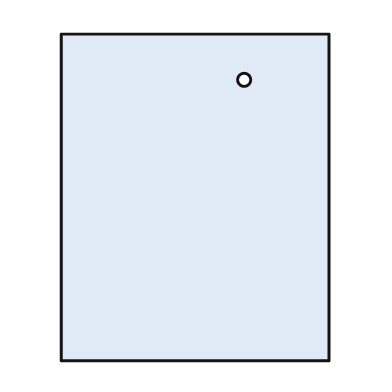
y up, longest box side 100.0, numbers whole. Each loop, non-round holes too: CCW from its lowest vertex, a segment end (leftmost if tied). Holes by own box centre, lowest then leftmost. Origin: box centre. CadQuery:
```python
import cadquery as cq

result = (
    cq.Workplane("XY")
    .moveTo(-41.0, -50.0)
    .lineTo(41.0, -50.0)
    .lineTo(41.0, 50.0)
    .lineTo(-41.0, 50.0)
    .close()
    .moveTo(15.0, 36.0)
    .circle(2.0)
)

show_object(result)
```